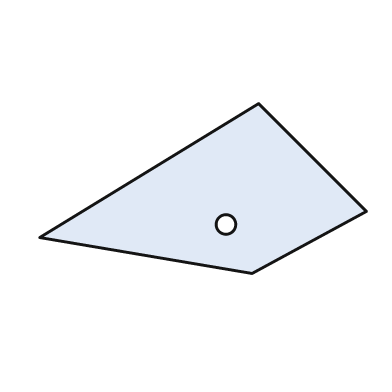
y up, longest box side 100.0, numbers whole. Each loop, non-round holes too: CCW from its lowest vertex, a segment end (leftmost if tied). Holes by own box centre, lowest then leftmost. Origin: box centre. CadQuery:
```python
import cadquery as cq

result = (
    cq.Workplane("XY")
    .moveTo(15.0, -26.0)
    .lineTo(50.0, -7.0)
    .lineTo(17.0, 26.0)
    .lineTo(-50.0, -15.0)
    .close()
    .moveTo(7.0, -11.0)
    .circle(3.0)
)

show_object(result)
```